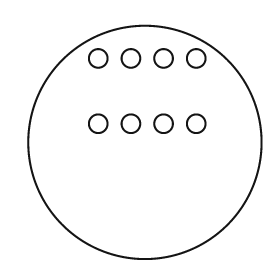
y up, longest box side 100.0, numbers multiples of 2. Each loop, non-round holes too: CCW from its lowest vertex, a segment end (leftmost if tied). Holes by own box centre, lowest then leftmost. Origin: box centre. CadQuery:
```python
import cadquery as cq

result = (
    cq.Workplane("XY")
    .moveTo(0.0, 0.0)
    .circle(50.0)
    .moveTo(-20.0, 8.0)
    .circle(4.0)
    .moveTo(-6.0, 8.0)
    .circle(4.0)
    .moveTo(8.0, 8.0)
    .circle(4.0)
    .moveTo(22.0, 8.0)
    .circle(4.0)
    .moveTo(-20.0, 36.0)
    .circle(4.0)
    .moveTo(-6.0, 36.0)
    .circle(4.0)
    .moveTo(8.0, 36.0)
    .circle(4.0)
    .moveTo(22.0, 36.0)
    .circle(4.0)
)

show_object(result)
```